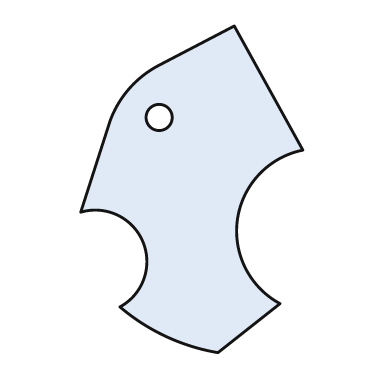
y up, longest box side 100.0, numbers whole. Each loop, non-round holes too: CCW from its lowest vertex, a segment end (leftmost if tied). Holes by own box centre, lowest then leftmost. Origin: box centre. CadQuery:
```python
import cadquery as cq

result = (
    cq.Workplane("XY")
    .moveTo(8.0, -50.0)
    .lineTo(27.0, -35.0)
    .threePointArc((14.0, -9.0), (34.0, 12.0))
    .lineTo(13.0, 50.0)
    .lineTo(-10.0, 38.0)
    .threePointArc((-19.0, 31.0), (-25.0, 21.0))
    .lineTo(-34.0, -7.0)
    .threePointArc((-15.0, -16.0), (-22.0, -36.0))
    .threePointArc((-8.0, -45.0), (8.0, -50.0))
    .close()
    .moveTo(-10.0, 22.0)
    .circle(4.0)
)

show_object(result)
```